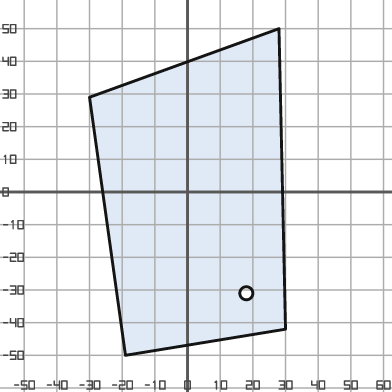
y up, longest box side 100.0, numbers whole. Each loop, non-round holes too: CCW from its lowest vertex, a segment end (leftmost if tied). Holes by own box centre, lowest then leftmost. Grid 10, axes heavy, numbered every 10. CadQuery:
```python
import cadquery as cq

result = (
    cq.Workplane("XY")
    .moveTo(-19.0, -50.0)
    .lineTo(30.0, -42.0)
    .lineTo(28.0, 50.0)
    .lineTo(-30.0, 29.0)
    .close()
    .moveTo(18.0, -31.0)
    .circle(2.0)
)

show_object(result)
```